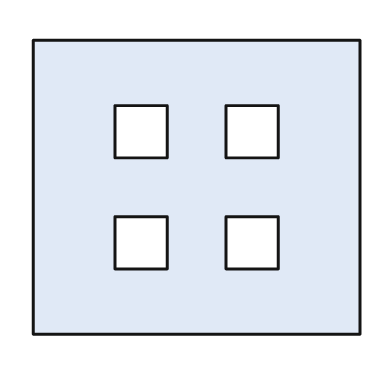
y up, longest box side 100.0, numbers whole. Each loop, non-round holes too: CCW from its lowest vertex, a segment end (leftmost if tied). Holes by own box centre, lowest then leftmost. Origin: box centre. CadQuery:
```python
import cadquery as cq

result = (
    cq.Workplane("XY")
    .moveTo(-50.0, -45.0)
    .lineTo(50.0, -45.0)
    .lineTo(50.0, 45.0)
    .lineTo(-50.0, 45.0)
    .close()
    .moveTo(-25.0, -25.0)
    .lineTo(-9.0, -25.0)
    .lineTo(-9.0, -9.0)
    .lineTo(-25.0, -9.0)
    .close()
    .moveTo(9.0, -25.0)
    .lineTo(25.0, -25.0)
    .lineTo(25.0, -9.0)
    .lineTo(9.0, -9.0)
    .close()
    .moveTo(-25.0, 9.0)
    .lineTo(-9.0, 9.0)
    .lineTo(-9.0, 25.0)
    .lineTo(-25.0, 25.0)
    .close()
    .moveTo(9.0, 9.0)
    .lineTo(25.0, 9.0)
    .lineTo(25.0, 25.0)
    .lineTo(9.0, 25.0)
    .close()
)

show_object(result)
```